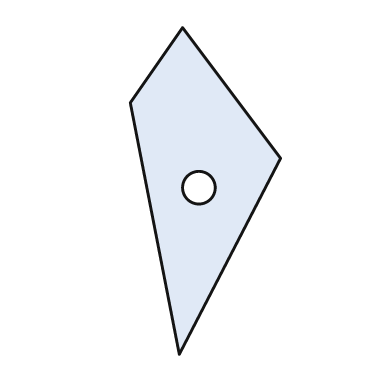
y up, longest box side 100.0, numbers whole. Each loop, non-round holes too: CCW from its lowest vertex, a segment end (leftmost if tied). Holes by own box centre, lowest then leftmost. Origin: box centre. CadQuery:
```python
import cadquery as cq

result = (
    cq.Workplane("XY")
    .moveTo(-8.0, -50.0)
    .lineTo(23.0, 10.0)
    .lineTo(-7.0, 50.0)
    .lineTo(-23.0, 27.0)
    .close()
    .moveTo(-2.0, 1.0)
    .circle(5.0)
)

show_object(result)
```